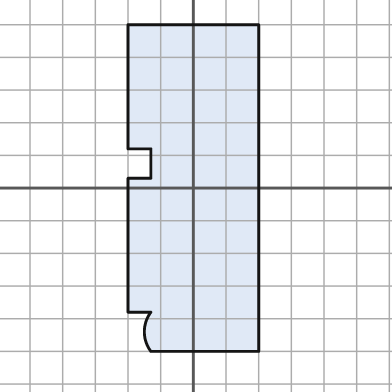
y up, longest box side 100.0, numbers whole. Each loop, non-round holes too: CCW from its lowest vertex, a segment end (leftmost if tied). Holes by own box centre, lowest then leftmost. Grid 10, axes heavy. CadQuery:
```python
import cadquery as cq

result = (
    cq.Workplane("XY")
    .moveTo(-13.0, -50.0)
    .lineTo(20.0, -50.0)
    .lineTo(20.0, 50.0)
    .lineTo(-20.0, 50.0)
    .lineTo(-20.0, 12.0)
    .lineTo(-13.0, 12.0)
    .lineTo(-13.0, 3.0)
    .lineTo(-20.0, 3.0)
    .lineTo(-20.0, -38.0)
    .lineTo(-13.0, -38.0)
    .threePointArc((-15.0, -44.0), (-13.0, -50.0))
    .close()
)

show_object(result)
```